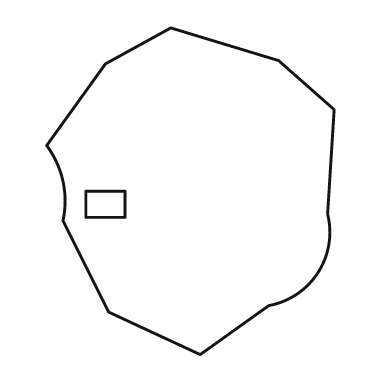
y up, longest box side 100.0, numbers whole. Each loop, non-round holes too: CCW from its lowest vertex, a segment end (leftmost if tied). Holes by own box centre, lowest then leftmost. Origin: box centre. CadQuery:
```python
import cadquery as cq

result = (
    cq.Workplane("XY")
    .moveTo(3.0, -50.0)
    .lineTo(24.0, -35.0)
    .threePointArc((39.0, -25.0), (42.0, -7.0))
    .lineTo(44.0, 25.0)
    .lineTo(27.0, 40.0)
    .lineTo(-6.0, 50.0)
    .lineTo(-26.0, 39.0)
    .lineTo(-44.0, 14.0)
    .threePointArc((-39.0, 3.0), (-39.0, -9.0))
    .lineTo(-25.0, -37.0)
    .close()
    .moveTo(-32.0, -8.0)
    .lineTo(-20.0, -8.0)
    .lineTo(-20.0, 0.0)
    .lineTo(-32.0, 0.0)
    .close()
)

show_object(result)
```